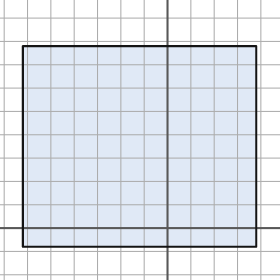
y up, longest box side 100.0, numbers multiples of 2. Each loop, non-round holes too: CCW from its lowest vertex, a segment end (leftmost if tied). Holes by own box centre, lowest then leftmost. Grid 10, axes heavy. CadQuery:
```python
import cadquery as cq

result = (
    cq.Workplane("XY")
    .moveTo(-62.0, -8.0)
    .lineTo(38.0, -8.0)
    .lineTo(38.0, 78.0)
    .lineTo(-62.0, 78.0)
    .close()
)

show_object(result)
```